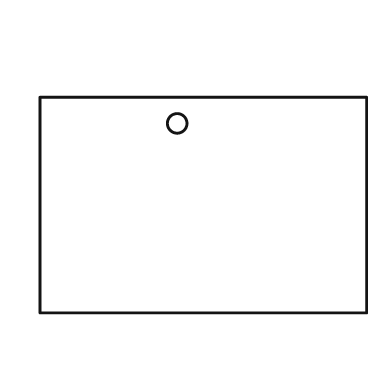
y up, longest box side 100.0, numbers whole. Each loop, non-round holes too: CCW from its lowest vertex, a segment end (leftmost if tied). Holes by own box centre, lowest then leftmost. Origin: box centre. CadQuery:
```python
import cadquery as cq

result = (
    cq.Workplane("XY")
    .moveTo(-50.0, -33.0)
    .lineTo(50.0, -33.0)
    .lineTo(50.0, 33.0)
    .lineTo(-50.0, 33.0)
    .close()
    .moveTo(-8.0, 25.0)
    .circle(3.0)
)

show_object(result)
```